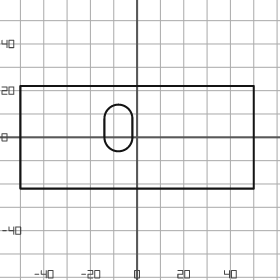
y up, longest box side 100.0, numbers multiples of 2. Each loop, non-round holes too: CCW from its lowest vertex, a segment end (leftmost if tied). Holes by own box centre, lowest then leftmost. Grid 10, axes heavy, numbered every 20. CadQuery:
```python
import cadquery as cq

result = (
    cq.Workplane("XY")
    .moveTo(-50.0, -22.0)
    .lineTo(50.0, -22.0)
    .lineTo(50.0, 22.0)
    .lineTo(-50.0, 22.0)
    .close()
    .moveTo(-14.0, 0.0)
    .threePointArc((-8.0, -6.0), (-2.0, 0.0))
    .lineTo(-2.0, 8.0)
    .threePointArc((-8.0, 14.0), (-14.0, 8.0))
    .close()
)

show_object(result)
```